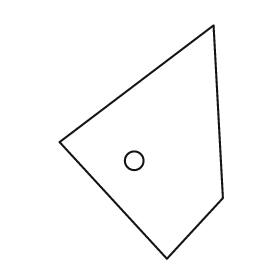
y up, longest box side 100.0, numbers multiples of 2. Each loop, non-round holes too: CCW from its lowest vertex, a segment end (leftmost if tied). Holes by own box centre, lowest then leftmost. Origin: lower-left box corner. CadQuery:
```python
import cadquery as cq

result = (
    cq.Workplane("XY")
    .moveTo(46.0, 0.0)
    .lineTo(70.0, 26.0)
    .lineTo(66.0, 100.0)
    .lineTo(0.0, 50.0)
    .close()
    .moveTo(32.0, 42.0)
    .circle(4.0)
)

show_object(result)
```